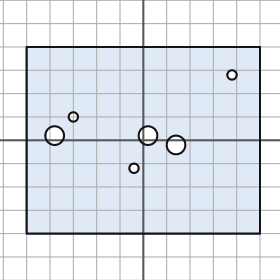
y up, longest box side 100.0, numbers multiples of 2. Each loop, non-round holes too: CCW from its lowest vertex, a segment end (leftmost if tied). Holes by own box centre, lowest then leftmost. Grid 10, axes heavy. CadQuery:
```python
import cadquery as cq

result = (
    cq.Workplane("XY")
    .moveTo(-50.0, -40.0)
    .lineTo(50.0, -40.0)
    .lineTo(50.0, 40.0)
    .lineTo(-50.0, 40.0)
    .close()
    .moveTo(-4.0, -12.0)
    .circle(2.0)
    .moveTo(14.0, -2.0)
    .circle(4.0)
    .moveTo(-38.0, 2.0)
    .circle(4.0)
    .moveTo(2.0, 2.0)
    .circle(4.0)
    .moveTo(-30.0, 10.0)
    .circle(2.0)
    .moveTo(38.0, 28.0)
    .circle(2.0)
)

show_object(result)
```